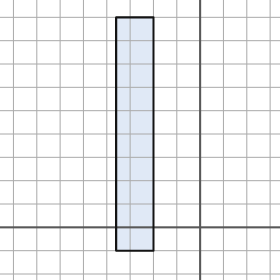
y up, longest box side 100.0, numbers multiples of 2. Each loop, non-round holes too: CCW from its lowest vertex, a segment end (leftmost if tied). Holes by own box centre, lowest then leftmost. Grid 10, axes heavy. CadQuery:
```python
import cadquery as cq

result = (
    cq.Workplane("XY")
    .moveTo(-36.0, -10.0)
    .lineTo(-20.0, -10.0)
    .lineTo(-20.0, 90.0)
    .lineTo(-36.0, 90.0)
    .close()
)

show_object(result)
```